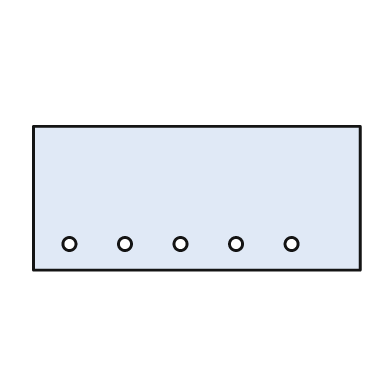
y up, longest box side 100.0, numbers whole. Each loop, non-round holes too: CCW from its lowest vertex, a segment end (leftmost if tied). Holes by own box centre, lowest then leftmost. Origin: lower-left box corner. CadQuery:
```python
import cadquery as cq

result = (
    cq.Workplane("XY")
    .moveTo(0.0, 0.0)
    .lineTo(100.0, 0.0)
    .lineTo(100.0, 44.0)
    .lineTo(0.0, 44.0)
    .close()
    .moveTo(11.0, 8.0)
    .circle(2.0)
    .moveTo(28.0, 8.0)
    .circle(2.0)
    .moveTo(45.0, 8.0)
    .circle(2.0)
    .moveTo(62.0, 8.0)
    .circle(2.0)
    .moveTo(79.0, 8.0)
    .circle(2.0)
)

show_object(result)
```